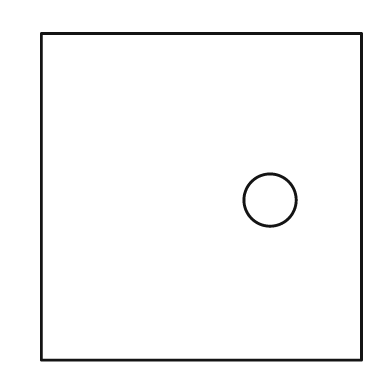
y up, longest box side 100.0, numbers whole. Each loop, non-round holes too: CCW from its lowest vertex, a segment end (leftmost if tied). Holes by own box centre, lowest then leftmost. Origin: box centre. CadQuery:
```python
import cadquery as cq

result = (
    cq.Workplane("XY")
    .moveTo(-49.0, -50.0)
    .lineTo(49.0, -50.0)
    .lineTo(49.0, 50.0)
    .lineTo(-49.0, 50.0)
    .close()
    .moveTo(21.0, -1.0)
    .circle(8.0)
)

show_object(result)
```